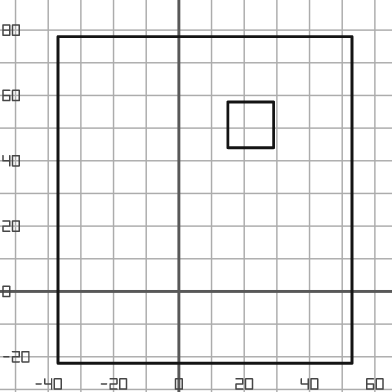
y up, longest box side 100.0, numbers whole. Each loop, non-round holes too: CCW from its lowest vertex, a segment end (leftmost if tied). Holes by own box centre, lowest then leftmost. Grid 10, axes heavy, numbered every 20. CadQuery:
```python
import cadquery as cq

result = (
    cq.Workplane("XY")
    .moveTo(-37.0, -22.0)
    .lineTo(53.0, -22.0)
    .lineTo(53.0, 78.0)
    .lineTo(-37.0, 78.0)
    .close()
    .moveTo(15.0, 44.0)
    .lineTo(29.0, 44.0)
    .lineTo(29.0, 58.0)
    .lineTo(15.0, 58.0)
    .close()
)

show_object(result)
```